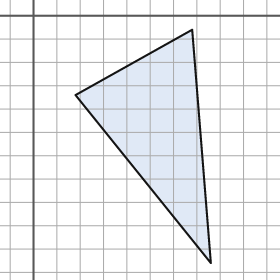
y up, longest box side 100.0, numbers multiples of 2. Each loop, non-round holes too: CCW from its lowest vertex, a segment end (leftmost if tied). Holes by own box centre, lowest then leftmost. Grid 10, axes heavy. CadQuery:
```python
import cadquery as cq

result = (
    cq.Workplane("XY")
    .moveTo(76.0, -106.0)
    .lineTo(68.0, -6.0)
    .lineTo(18.0, -34.0)
    .close()
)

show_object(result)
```